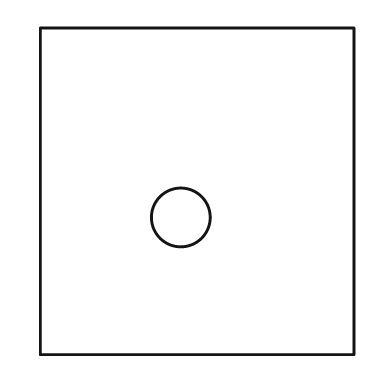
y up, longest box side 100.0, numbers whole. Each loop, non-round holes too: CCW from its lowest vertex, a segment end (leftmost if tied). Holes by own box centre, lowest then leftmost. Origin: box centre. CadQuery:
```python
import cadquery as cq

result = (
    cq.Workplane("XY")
    .moveTo(-48.0, -50.0)
    .lineTo(48.0, -50.0)
    .lineTo(48.0, 50.0)
    .lineTo(-48.0, 50.0)
    .close()
    .moveTo(-5.0, -8.0)
    .circle(9.0)
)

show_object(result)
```